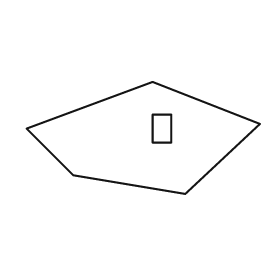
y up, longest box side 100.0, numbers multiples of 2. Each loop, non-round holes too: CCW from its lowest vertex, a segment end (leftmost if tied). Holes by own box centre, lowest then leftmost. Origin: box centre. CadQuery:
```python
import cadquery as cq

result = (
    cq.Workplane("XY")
    .moveTo(18.0, -24.0)
    .lineTo(50.0, 6.0)
    .lineTo(4.0, 24.0)
    .lineTo(-50.0, 4.0)
    .lineTo(-30.0, -16.0)
    .close()
    .moveTo(4.0, -2.0)
    .lineTo(12.0, -2.0)
    .lineTo(12.0, 10.0)
    .lineTo(4.0, 10.0)
    .close()
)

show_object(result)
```